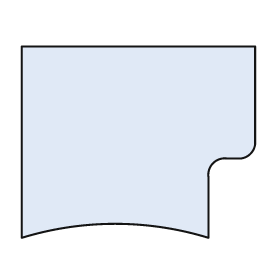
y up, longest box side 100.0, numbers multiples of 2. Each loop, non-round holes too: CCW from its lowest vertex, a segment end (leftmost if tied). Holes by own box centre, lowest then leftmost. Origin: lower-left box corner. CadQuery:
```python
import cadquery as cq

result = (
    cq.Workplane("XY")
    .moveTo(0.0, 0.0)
    .threePointArc((40.0, 6.0), (80.0, 0.0))
    .lineTo(80.0, 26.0)
    .threePointArc((82.0, 32.0), (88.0, 34.0))
    .lineTo(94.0, 34.0)
    .threePointArc((98.0, 36.0), (100.0, 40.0))
    .lineTo(100.0, 82.0)
    .lineTo(0.0, 82.0)
    .close()
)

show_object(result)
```